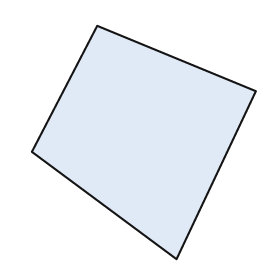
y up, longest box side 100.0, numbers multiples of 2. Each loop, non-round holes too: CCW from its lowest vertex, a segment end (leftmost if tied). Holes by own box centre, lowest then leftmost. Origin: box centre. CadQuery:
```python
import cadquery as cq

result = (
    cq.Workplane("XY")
    .moveTo(14.0, -50.0)
    .lineTo(48.0, 22.0)
    .lineTo(-20.0, 50.0)
    .lineTo(-48.0, -4.0)
    .close()
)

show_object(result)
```